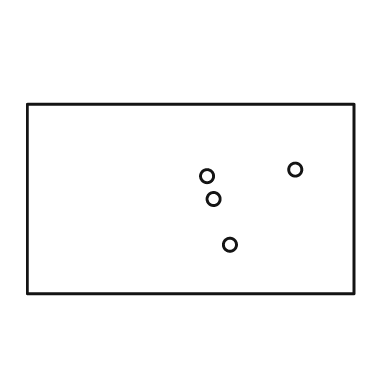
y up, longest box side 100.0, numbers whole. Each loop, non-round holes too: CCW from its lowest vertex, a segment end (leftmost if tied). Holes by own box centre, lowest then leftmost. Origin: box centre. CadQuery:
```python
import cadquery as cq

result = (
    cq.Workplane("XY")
    .moveTo(-50.0, -29.0)
    .lineTo(50.0, -29.0)
    .lineTo(50.0, 29.0)
    .lineTo(-50.0, 29.0)
    .close()
    .moveTo(12.0, -14.0)
    .circle(2.0)
    .moveTo(7.0, 0.0)
    .circle(2.0)
    .moveTo(5.0, 7.0)
    .circle(2.0)
    .moveTo(32.0, 9.0)
    .circle(2.0)
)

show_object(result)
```